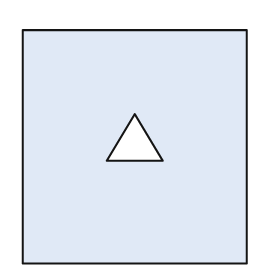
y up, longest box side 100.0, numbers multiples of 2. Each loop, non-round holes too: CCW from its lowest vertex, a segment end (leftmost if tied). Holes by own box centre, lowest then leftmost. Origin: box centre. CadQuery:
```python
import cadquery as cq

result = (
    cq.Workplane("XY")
    .moveTo(-48.0, -50.0)
    .lineTo(48.0, -50.0)
    .lineTo(48.0, 50.0)
    .lineTo(-48.0, 50.0)
    .close()
    .moveTo(-12.0, -6.0)
    .lineTo(12.0, -6.0)
    .lineTo(0.0, 14.0)
    .close()
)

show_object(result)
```